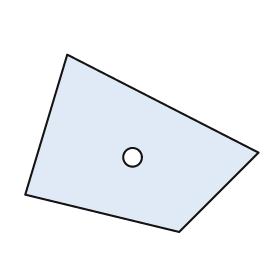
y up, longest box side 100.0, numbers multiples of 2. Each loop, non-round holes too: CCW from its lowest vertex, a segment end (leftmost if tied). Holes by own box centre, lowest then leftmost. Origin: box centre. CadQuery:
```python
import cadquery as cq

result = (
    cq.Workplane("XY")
    .moveTo(16.0, -38.0)
    .lineTo(50.0, -4.0)
    .lineTo(-32.0, 38.0)
    .lineTo(-50.0, -22.0)
    .close()
    .moveTo(-4.0, -6.0)
    .circle(4.0)
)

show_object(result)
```